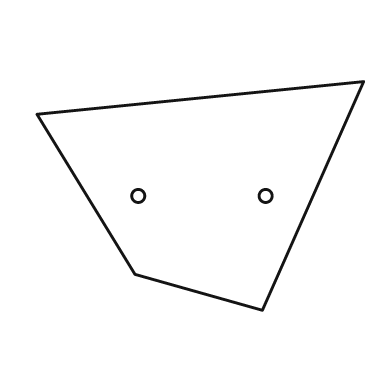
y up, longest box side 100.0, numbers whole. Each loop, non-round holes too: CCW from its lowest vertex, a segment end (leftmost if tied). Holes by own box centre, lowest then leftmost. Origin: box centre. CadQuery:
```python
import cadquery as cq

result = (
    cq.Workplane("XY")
    .moveTo(19.0, -35.0)
    .lineTo(50.0, 35.0)
    .lineTo(-50.0, 25.0)
    .lineTo(-20.0, -24.0)
    .close()
    .moveTo(-19.0, 0.0)
    .circle(2.0)
    .moveTo(20.0, 0.0)
    .circle(2.0)
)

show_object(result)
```